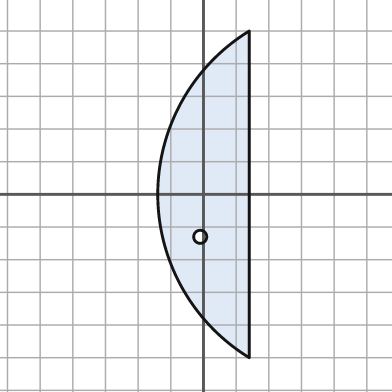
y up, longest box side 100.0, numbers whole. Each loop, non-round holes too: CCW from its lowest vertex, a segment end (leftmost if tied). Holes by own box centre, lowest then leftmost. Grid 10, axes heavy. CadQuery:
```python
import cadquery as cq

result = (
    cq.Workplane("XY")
    .moveTo(14.0, -50.0)
    .lineTo(14.0, 50.0)
    .threePointArc((-14.0, 0.0), (14.0, -50.0))
    .close()
    .moveTo(-1.0, -13.0)
    .circle(2.0)
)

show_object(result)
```